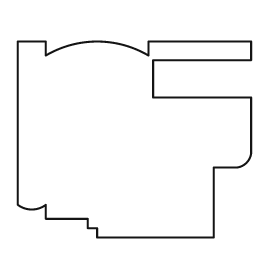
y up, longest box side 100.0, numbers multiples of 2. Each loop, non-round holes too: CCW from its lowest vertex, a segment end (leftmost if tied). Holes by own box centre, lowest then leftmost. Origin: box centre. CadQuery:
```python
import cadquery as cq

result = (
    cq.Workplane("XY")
    .moveTo(-16.0, -42.0)
    .lineTo(34.0, -42.0)
    .lineTo(34.0, -12.0)
    .lineTo(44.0, -12.0)
    .threePointArc((48.0, -10.0), (50.0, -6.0))
    .lineTo(50.0, 18.0)
    .lineTo(8.0, 18.0)
    .lineTo(8.0, 34.0)
    .lineTo(50.0, 34.0)
    .lineTo(50.0, 42.0)
    .lineTo(6.0, 42.0)
    .lineTo(6.0, 36.0)
    .threePointArc((-16.0, 42.0), (-38.0, 36.0))
    .lineTo(-38.0, 42.0)
    .lineTo(-50.0, 42.0)
    .lineTo(-50.0, -28.0)
    .threePointArc((-44.0, -30.0), (-38.0, -28.0))
    .lineTo(-38.0, -34.0)
    .lineTo(-20.0, -34.0)
    .lineTo(-20.0, -38.0)
    .lineTo(-16.0, -38.0)
    .close()
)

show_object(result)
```